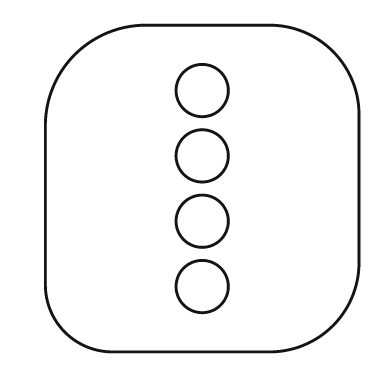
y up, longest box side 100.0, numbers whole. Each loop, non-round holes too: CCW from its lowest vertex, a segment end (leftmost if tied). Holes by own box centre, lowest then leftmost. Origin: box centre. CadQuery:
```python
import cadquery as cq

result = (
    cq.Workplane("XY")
    .moveTo(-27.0, -50.0)
    .lineTo(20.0, -50.0)
    .threePointArc((40.0, -42.0), (48.0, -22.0))
    .lineTo(48.0, 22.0)
    .threePointArc((40.0, 42.0), (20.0, 50.0))
    .lineTo(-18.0, 50.0)
    .threePointArc((-39.0, 41.0), (-48.0, 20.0))
    .lineTo(-48.0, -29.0)
    .threePointArc((-42.0, -44.0), (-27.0, -50.0))
    .close()
    .moveTo(0.0, -30.0)
    .circle(8.0)
    .moveTo(0.0, -10.0)
    .circle(8.0)
    .moveTo(0.0, 10.0)
    .circle(8.0)
    .moveTo(0.0, 30.0)
    .circle(8.0)
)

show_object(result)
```